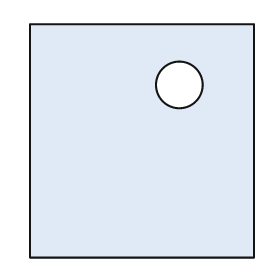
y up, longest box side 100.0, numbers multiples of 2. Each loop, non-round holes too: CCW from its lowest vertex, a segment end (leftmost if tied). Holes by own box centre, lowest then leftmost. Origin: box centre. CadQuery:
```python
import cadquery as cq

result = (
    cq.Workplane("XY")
    .moveTo(-48.0, -50.0)
    .lineTo(48.0, -50.0)
    .lineTo(48.0, 50.0)
    .lineTo(-48.0, 50.0)
    .close()
    .moveTo(16.0, 24.0)
    .circle(10.0)
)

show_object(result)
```